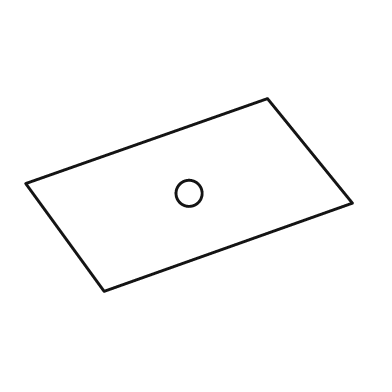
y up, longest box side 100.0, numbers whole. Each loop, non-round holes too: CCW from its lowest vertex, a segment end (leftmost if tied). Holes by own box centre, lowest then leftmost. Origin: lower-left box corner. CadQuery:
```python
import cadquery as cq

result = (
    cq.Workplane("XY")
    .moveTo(24.0, 0.0)
    .lineTo(100.0, 27.0)
    .lineTo(74.0, 59.0)
    .lineTo(0.0, 33.0)
    .close()
    .moveTo(50.0, 30.0)
    .circle(4.0)
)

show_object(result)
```